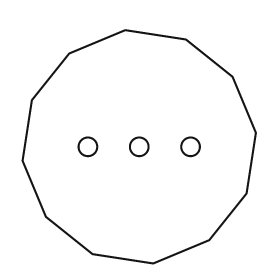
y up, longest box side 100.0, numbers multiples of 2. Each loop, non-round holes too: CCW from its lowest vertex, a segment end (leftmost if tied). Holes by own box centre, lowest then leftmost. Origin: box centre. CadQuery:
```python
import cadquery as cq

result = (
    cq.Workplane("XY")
    .moveTo(6.0, -50.0)
    .lineTo(30.0, -40.0)
    .lineTo(46.0, -20.0)
    .lineTo(50.0, 6.0)
    .lineTo(40.0, 30.0)
    .lineTo(20.0, 46.0)
    .lineTo(-6.0, 50.0)
    .lineTo(-30.0, 40.0)
    .lineTo(-46.0, 20.0)
    .lineTo(-50.0, -6.0)
    .lineTo(-40.0, -30.0)
    .lineTo(-20.0, -46.0)
    .close()
    .moveTo(-22.0, 0.0)
    .circle(4.0)
    .moveTo(0.0, 0.0)
    .circle(4.0)
    .moveTo(22.0, 0.0)
    .circle(4.0)
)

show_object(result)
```